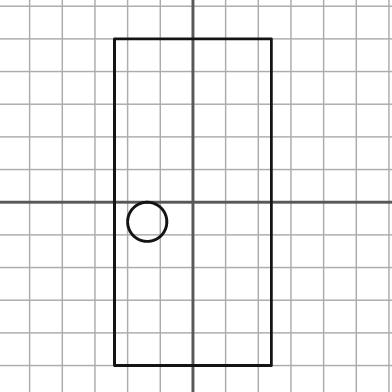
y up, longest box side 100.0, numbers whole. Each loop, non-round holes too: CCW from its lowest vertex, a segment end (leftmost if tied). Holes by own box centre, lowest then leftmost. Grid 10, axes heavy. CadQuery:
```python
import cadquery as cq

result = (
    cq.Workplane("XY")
    .moveTo(-24.0, -50.0)
    .lineTo(24.0, -50.0)
    .lineTo(24.0, 50.0)
    .lineTo(-24.0, 50.0)
    .close()
    .moveTo(-14.0, -6.0)
    .circle(6.0)
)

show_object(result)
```